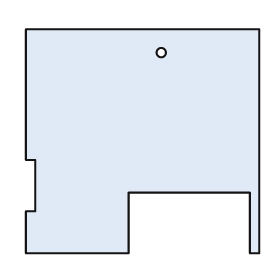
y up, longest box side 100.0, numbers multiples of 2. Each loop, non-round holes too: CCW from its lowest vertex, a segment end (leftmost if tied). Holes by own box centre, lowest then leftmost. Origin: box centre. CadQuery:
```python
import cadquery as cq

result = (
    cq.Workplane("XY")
    .moveTo(-50.0, -48.0)
    .lineTo(-6.0, -48.0)
    .lineTo(-6.0, -22.0)
    .lineTo(46.0, -22.0)
    .lineTo(46.0, -48.0)
    .lineTo(50.0, -48.0)
    .lineTo(50.0, 48.0)
    .lineTo(-50.0, 48.0)
    .lineTo(-50.0, -8.0)
    .lineTo(-46.0, -8.0)
    .lineTo(-46.0, -30.0)
    .lineTo(-50.0, -30.0)
    .close()
    .moveTo(8.0, 38.0)
    .circle(2.0)
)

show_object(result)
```